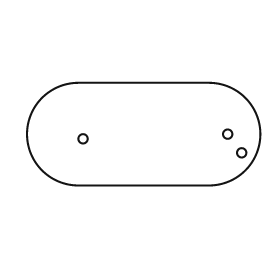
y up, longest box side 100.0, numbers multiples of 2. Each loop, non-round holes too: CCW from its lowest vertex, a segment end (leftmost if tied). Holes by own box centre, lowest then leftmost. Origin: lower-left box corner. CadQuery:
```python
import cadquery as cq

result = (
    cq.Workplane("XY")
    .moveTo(22.0, 0.0)
    .lineTo(78.0, 0.0)
    .threePointArc((100.0, 22.0), (78.0, 44.0))
    .lineTo(22.0, 44.0)
    .threePointArc((0.0, 22.0), (22.0, 0.0))
    .close()
    .moveTo(92.0, 14.0)
    .circle(2.0)
    .moveTo(24.0, 20.0)
    .circle(2.0)
    .moveTo(86.0, 22.0)
    .circle(2.0)
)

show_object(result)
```